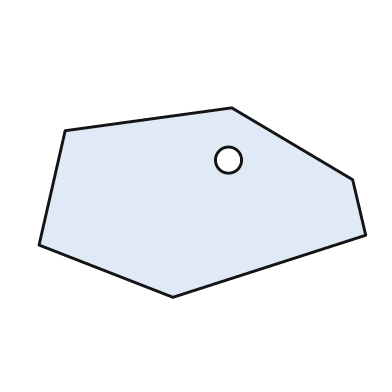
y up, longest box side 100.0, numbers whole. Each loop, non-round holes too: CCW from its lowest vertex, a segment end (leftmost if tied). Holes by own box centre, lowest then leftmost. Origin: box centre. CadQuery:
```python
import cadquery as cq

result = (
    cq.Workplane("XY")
    .moveTo(-9.0, -29.0)
    .lineTo(50.0, -10.0)
    .lineTo(46.0, 7.0)
    .lineTo(9.0, 29.0)
    .lineTo(-42.0, 22.0)
    .lineTo(-50.0, -13.0)
    .close()
    .moveTo(8.0, 13.0)
    .circle(4.0)
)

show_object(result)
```